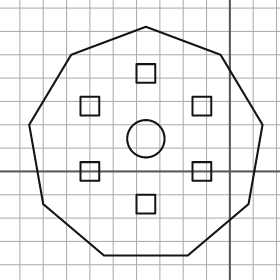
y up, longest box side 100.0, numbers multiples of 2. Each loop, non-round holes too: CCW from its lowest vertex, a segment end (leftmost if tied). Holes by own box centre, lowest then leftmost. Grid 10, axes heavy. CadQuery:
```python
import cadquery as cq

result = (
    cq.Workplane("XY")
    .moveTo(-54.0, -36.0)
    .lineTo(-18.0, -36.0)
    .lineTo(8.0, -14.0)
    .lineTo(14.0, 20.0)
    .lineTo(-4.0, 50.0)
    .lineTo(-36.0, 62.0)
    .lineTo(-68.0, 50.0)
    .lineTo(-86.0, 20.0)
    .lineTo(-80.0, -14.0)
    .close()
    .moveTo(-40.0, -18.0)
    .lineTo(-32.0, -18.0)
    .lineTo(-32.0, -10.0)
    .lineTo(-40.0, -10.0)
    .close()
    .moveTo(-64.0, -4.0)
    .lineTo(-56.0, -4.0)
    .lineTo(-56.0, 4.0)
    .lineTo(-64.0, 4.0)
    .close()
    .moveTo(-16.0, -4.0)
    .lineTo(-8.0, -4.0)
    .lineTo(-8.0, 4.0)
    .lineTo(-16.0, 4.0)
    .close()
    .moveTo(-36.0, 14.0)
    .circle(8.0)
    .moveTo(-64.0, 24.0)
    .lineTo(-56.0, 24.0)
    .lineTo(-56.0, 32.0)
    .lineTo(-64.0, 32.0)
    .close()
    .moveTo(-16.0, 24.0)
    .lineTo(-8.0, 24.0)
    .lineTo(-8.0, 32.0)
    .lineTo(-16.0, 32.0)
    .close()
    .moveTo(-40.0, 38.0)
    .lineTo(-32.0, 38.0)
    .lineTo(-32.0, 46.0)
    .lineTo(-40.0, 46.0)
    .close()
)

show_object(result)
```